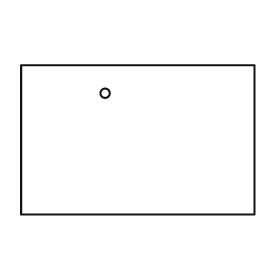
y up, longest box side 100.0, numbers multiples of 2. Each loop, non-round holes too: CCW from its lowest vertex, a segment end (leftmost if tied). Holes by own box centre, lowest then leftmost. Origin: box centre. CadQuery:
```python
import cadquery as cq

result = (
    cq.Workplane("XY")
    .moveTo(-50.0, -32.0)
    .lineTo(50.0, -32.0)
    .lineTo(50.0, 32.0)
    .lineTo(-50.0, 32.0)
    .close()
    .moveTo(-14.0, 20.0)
    .circle(2.0)
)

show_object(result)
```